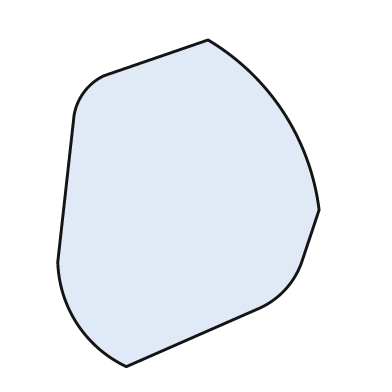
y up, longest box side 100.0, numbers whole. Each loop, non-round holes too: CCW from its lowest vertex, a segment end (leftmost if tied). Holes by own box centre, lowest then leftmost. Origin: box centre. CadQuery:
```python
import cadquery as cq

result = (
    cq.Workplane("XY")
    .moveTo(-19.0, -50.0)
    .lineTo(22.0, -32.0)
    .threePointArc((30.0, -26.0), (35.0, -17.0))
    .lineTo(40.0, -2.0)
    .threePointArc((29.0, 28.0), (6.0, 50.0))
    .lineTo(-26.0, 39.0)
    .threePointArc((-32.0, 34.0), (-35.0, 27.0))
    .lineTo(-40.0, -18.0)
    .threePointArc((-34.0, -37.0), (-19.0, -50.0))
    .close()
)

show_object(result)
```